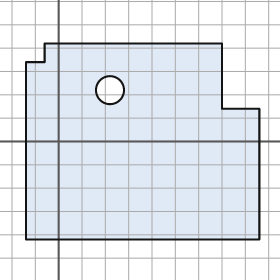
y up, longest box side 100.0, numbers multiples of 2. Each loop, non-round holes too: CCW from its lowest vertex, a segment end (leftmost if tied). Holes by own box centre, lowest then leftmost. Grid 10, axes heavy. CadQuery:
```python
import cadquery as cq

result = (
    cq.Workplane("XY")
    .moveTo(-14.0, -42.0)
    .lineTo(86.0, -42.0)
    .lineTo(86.0, 14.0)
    .lineTo(70.0, 14.0)
    .lineTo(70.0, 42.0)
    .lineTo(-6.0, 42.0)
    .lineTo(-6.0, 34.0)
    .lineTo(-14.0, 34.0)
    .close()
    .moveTo(22.0, 22.0)
    .circle(6.0)
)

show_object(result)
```